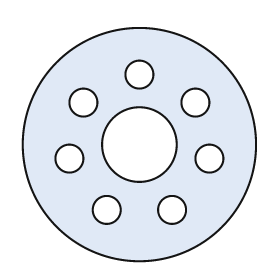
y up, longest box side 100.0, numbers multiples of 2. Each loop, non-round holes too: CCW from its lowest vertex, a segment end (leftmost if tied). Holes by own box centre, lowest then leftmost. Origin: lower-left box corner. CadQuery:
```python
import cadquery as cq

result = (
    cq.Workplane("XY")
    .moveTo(50.0, 50.0)
    .circle(50.0)
    .moveTo(36.0, 22.0)
    .circle(6.0)
    .moveTo(64.0, 22.0)
    .circle(6.0)
    .moveTo(20.0, 44.0)
    .circle(6.0)
    .moveTo(80.0, 44.0)
    .circle(6.0)
    .moveTo(50.0, 50.0)
    .circle(16.0)
    .moveTo(26.0, 68.0)
    .circle(6.0)
    .moveTo(74.0, 68.0)
    .circle(6.0)
    .moveTo(50.0, 80.0)
    .circle(6.0)
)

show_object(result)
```